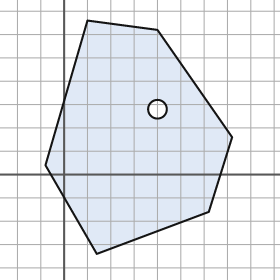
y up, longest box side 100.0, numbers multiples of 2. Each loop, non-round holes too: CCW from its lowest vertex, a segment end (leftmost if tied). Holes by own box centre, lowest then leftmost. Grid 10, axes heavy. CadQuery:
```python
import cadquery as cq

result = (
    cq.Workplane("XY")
    .moveTo(14.0, -34.0)
    .lineTo(62.0, -16.0)
    .lineTo(72.0, 16.0)
    .lineTo(40.0, 62.0)
    .lineTo(10.0, 66.0)
    .lineTo(-8.0, 4.0)
    .close()
    .moveTo(40.0, 28.0)
    .circle(4.0)
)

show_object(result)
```